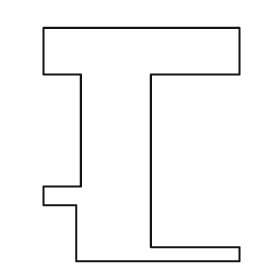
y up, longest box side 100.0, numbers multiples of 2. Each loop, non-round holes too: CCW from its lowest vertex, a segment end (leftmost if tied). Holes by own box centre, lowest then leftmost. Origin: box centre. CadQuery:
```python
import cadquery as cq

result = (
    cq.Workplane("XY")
    .moveTo(-28.0, -50.0)
    .lineTo(42.0, -50.0)
    .lineTo(42.0, -44.0)
    .lineTo(4.0, -44.0)
    .lineTo(4.0, 30.0)
    .lineTo(42.0, 30.0)
    .lineTo(42.0, 50.0)
    .lineTo(-42.0, 50.0)
    .lineTo(-42.0, 30.0)
    .lineTo(-26.0, 30.0)
    .lineTo(-26.0, -18.0)
    .lineTo(-42.0, -18.0)
    .lineTo(-42.0, -26.0)
    .lineTo(-28.0, -26.0)
    .close()
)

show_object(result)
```